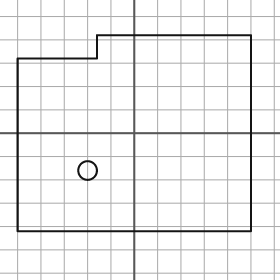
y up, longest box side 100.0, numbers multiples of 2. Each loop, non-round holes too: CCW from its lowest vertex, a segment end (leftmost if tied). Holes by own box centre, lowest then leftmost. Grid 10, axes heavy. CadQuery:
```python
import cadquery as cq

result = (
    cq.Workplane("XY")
    .moveTo(-50.0, -42.0)
    .lineTo(50.0, -42.0)
    .lineTo(50.0, 42.0)
    .lineTo(-16.0, 42.0)
    .lineTo(-16.0, 32.0)
    .lineTo(-50.0, 32.0)
    .close()
    .moveTo(-20.0, -16.0)
    .circle(4.0)
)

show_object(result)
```